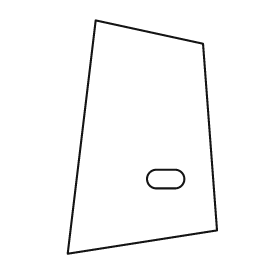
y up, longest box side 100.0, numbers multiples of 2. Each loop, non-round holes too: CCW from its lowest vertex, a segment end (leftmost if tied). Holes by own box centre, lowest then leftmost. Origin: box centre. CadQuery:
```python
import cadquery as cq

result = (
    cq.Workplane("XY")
    .moveTo(-32.0, -50.0)
    .lineTo(32.0, -40.0)
    .lineTo(26.0, 40.0)
    .lineTo(-20.0, 50.0)
    .close()
    .moveTo(6.0, -22.0)
    .lineTo(14.0, -22.0)
    .threePointArc((18.0, -18.0), (14.0, -14.0))
    .lineTo(6.0, -14.0)
    .threePointArc((2.0, -18.0), (6.0, -22.0))
    .close()
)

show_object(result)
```